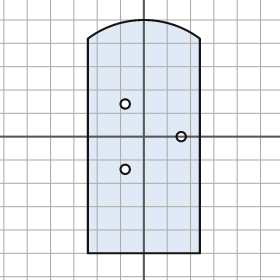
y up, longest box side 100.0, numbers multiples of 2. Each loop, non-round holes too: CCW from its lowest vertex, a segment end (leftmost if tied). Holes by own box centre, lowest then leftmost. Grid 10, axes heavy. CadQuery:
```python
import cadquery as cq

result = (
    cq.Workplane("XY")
    .moveTo(-24.0, -50.0)
    .lineTo(24.0, -50.0)
    .lineTo(24.0, 42.0)
    .threePointArc((0.0, 50.0), (-24.0, 42.0))
    .close()
    .moveTo(-8.0, -14.0)
    .circle(2.0)
    .moveTo(16.0, 0.0)
    .circle(2.0)
    .moveTo(-8.0, 14.0)
    .circle(2.0)
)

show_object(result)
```